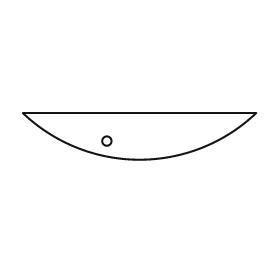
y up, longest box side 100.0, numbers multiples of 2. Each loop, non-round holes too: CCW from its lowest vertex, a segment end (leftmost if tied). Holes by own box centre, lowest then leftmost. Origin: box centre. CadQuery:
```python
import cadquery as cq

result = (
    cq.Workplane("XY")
    .moveTo(-50.0, 10.0)
    .threePointArc((0.0, -10.0), (50.0, 10.0))
    .close()
    .moveTo(-14.0, -2.0)
    .circle(2.0)
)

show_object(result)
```